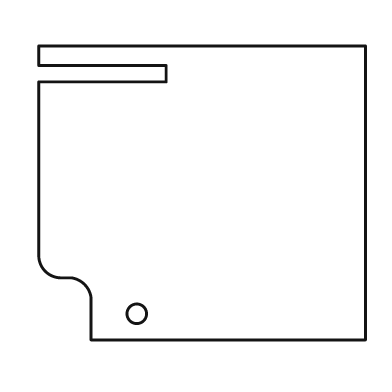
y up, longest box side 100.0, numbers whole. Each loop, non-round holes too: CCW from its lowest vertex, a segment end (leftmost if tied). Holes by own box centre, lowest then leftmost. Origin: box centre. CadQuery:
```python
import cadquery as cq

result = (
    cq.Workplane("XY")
    .moveTo(-34.0, -45.0)
    .lineTo(50.0, -45.0)
    .lineTo(50.0, 45.0)
    .lineTo(-50.0, 45.0)
    .lineTo(-50.0, 39.0)
    .lineTo(-11.0, 39.0)
    .lineTo(-11.0, 34.0)
    .lineTo(-50.0, 34.0)
    .lineTo(-50.0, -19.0)
    .threePointArc((-48.0, -24.0), (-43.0, -26.0))
    .lineTo(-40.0, -26.0)
    .threePointArc((-36.0, -28.0), (-34.0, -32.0))
    .close()
    .moveTo(-20.0, -37.0)
    .circle(3.0)
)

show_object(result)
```